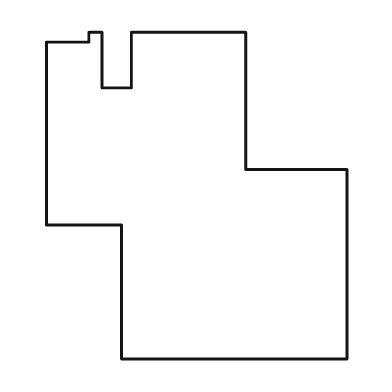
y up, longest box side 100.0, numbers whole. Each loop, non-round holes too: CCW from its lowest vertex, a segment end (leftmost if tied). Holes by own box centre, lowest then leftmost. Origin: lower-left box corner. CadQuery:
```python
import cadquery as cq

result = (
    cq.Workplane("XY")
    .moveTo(23.0, 0.0)
    .lineTo(92.0, 0.0)
    .lineTo(92.0, 58.0)
    .lineTo(61.0, 58.0)
    .lineTo(61.0, 100.0)
    .lineTo(26.0, 100.0)
    .lineTo(26.0, 83.0)
    .lineTo(17.0, 83.0)
    .lineTo(17.0, 100.0)
    .lineTo(13.0, 100.0)
    .lineTo(13.0, 97.0)
    .lineTo(0.0, 97.0)
    .lineTo(0.0, 41.0)
    .lineTo(23.0, 41.0)
    .close()
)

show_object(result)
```